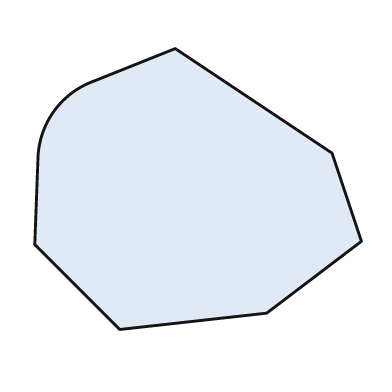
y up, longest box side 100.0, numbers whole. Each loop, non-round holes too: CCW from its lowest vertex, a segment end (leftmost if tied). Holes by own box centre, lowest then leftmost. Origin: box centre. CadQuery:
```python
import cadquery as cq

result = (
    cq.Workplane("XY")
    .moveTo(-24.0, -43.0)
    .lineTo(21.0, -38.0)
    .lineTo(50.0, -16.0)
    .lineTo(41.0, 11.0)
    .lineTo(-7.0, 43.0)
    .lineTo(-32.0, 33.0)
    .threePointArc((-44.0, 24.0), (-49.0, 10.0))
    .lineTo(-50.0, -17.0)
    .close()
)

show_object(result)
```